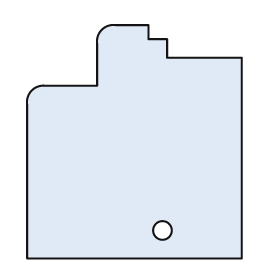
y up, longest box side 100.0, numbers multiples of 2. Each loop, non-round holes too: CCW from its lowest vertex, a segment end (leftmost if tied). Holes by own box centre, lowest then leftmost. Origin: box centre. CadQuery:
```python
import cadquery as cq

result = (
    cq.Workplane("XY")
    .moveTo(-46.0, -50.0)
    .lineTo(46.0, -50.0)
    .lineTo(46.0, 36.0)
    .lineTo(14.0, 36.0)
    .lineTo(14.0, 44.0)
    .lineTo(6.0, 44.0)
    .lineTo(6.0, 50.0)
    .lineTo(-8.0, 50.0)
    .threePointArc((-14.0, 48.0), (-16.0, 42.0))
    .lineTo(-16.0, 24.0)
    .lineTo(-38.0, 24.0)
    .threePointArc((-44.0, 22.0), (-46.0, 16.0))
    .close()
    .moveTo(12.0, -38.0)
    .circle(4.0)
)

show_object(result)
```